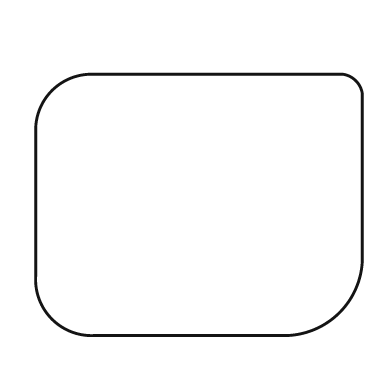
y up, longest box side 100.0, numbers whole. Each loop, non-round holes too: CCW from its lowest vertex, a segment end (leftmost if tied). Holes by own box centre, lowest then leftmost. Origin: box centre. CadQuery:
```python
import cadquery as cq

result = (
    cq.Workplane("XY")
    .moveTo(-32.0, -40.0)
    .lineTo(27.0, -40.0)
    .threePointArc((43.0, -33.0), (50.0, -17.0))
    .lineTo(50.0, 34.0)
    .threePointArc((48.0, 38.0), (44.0, 40.0))
    .lineTo(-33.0, 40.0)
    .threePointArc((-45.0, 35.0), (-50.0, 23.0))
    .lineTo(-50.0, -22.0)
    .threePointArc((-45.0, -35.0), (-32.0, -40.0))
    .close()
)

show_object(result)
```